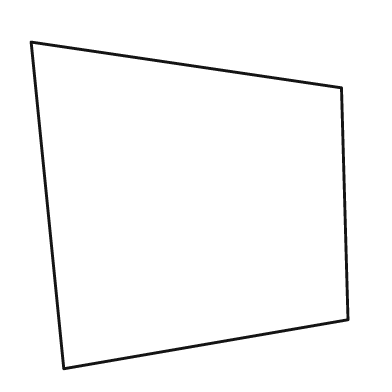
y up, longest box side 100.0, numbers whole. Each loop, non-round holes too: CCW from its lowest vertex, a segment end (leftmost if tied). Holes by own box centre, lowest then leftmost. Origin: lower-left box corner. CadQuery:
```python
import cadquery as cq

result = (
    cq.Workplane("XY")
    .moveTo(10.0, 0.0)
    .lineTo(97.0, 15.0)
    .lineTo(95.0, 86.0)
    .lineTo(0.0, 100.0)
    .close()
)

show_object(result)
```